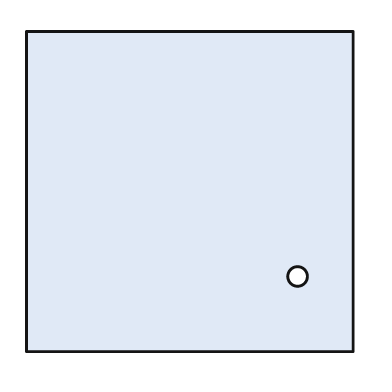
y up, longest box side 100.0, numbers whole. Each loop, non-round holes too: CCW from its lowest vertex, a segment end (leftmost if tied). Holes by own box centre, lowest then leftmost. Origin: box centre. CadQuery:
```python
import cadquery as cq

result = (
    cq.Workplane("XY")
    .moveTo(-50.0, -49.0)
    .lineTo(50.0, -49.0)
    .lineTo(50.0, 49.0)
    .lineTo(-50.0, 49.0)
    .close()
    .moveTo(33.0, -26.0)
    .circle(3.0)
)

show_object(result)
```